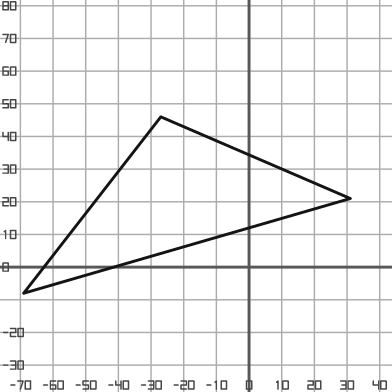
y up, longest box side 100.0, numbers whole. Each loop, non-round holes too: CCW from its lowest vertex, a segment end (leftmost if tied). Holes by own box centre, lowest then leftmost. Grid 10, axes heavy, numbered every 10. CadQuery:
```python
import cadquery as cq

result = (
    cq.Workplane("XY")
    .moveTo(-69.0, -8.0)
    .lineTo(31.0, 21.0)
    .lineTo(-27.0, 46.0)
    .close()
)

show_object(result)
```